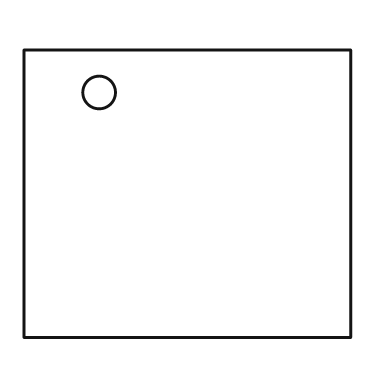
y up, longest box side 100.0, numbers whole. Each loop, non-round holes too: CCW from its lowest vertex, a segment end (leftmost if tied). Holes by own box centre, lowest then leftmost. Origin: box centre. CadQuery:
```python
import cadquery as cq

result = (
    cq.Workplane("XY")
    .moveTo(-50.0, -44.0)
    .lineTo(50.0, -44.0)
    .lineTo(50.0, 44.0)
    .lineTo(-50.0, 44.0)
    .close()
    .moveTo(-27.0, 31.0)
    .circle(5.0)
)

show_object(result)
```